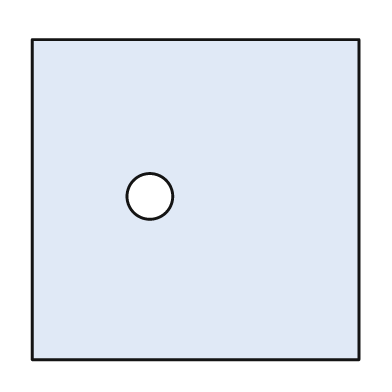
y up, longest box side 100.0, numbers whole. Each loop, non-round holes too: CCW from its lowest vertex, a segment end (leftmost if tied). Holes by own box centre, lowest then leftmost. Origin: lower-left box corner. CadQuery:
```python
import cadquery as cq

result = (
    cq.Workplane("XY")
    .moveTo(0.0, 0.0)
    .lineTo(100.0, 0.0)
    .lineTo(100.0, 98.0)
    .lineTo(0.0, 98.0)
    .close()
    .moveTo(36.0, 50.0)
    .circle(7.0)
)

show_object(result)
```